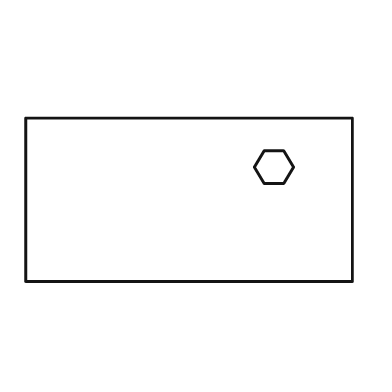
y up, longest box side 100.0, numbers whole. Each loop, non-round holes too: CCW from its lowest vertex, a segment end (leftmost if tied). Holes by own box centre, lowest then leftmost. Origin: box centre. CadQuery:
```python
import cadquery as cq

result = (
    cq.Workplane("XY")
    .moveTo(-50.0, -25.0)
    .lineTo(50.0, -25.0)
    .lineTo(50.0, 25.0)
    .lineTo(-50.0, 25.0)
    .close()
    .moveTo(23.0, 5.0)
    .lineTo(29.0, 5.0)
    .lineTo(32.0, 10.0)
    .lineTo(29.0, 15.0)
    .lineTo(23.0, 15.0)
    .lineTo(20.0, 10.0)
    .close()
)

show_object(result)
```